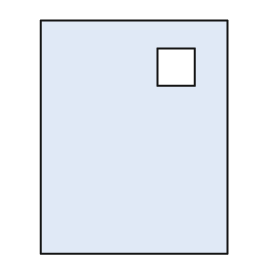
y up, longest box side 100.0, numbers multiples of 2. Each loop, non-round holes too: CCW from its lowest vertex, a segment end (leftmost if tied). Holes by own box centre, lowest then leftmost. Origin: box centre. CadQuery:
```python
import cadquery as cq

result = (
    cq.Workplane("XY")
    .moveTo(-40.0, -50.0)
    .lineTo(40.0, -50.0)
    .lineTo(40.0, 50.0)
    .lineTo(-40.0, 50.0)
    .close()
    .moveTo(10.0, 22.0)
    .lineTo(26.0, 22.0)
    .lineTo(26.0, 38.0)
    .lineTo(10.0, 38.0)
    .close()
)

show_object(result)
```